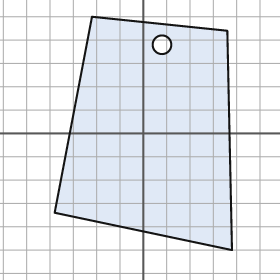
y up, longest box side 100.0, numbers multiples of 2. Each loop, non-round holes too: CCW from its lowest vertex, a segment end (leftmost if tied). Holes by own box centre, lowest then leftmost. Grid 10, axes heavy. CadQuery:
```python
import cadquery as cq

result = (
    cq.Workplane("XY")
    .moveTo(38.0, -50.0)
    .lineTo(36.0, 44.0)
    .lineTo(-22.0, 50.0)
    .lineTo(-38.0, -34.0)
    .close()
    .moveTo(8.0, 38.0)
    .circle(4.0)
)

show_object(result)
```